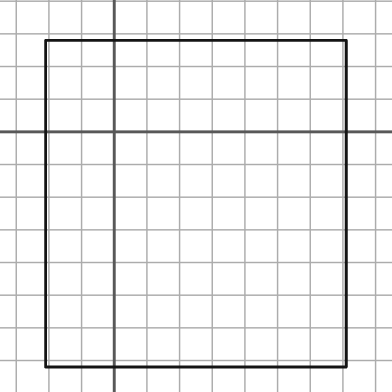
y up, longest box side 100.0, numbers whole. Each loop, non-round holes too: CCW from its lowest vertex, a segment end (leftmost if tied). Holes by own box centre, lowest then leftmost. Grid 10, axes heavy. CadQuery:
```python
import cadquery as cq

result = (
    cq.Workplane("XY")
    .moveTo(-21.0, -72.0)
    .lineTo(71.0, -72.0)
    .lineTo(71.0, 28.0)
    .lineTo(-21.0, 28.0)
    .close()
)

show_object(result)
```